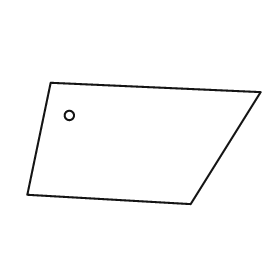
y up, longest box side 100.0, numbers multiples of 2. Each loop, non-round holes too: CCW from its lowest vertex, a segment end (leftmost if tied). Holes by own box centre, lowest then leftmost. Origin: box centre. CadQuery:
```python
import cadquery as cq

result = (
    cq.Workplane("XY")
    .moveTo(20.0, -26.0)
    .lineTo(50.0, 22.0)
    .lineTo(-40.0, 26.0)
    .lineTo(-50.0, -22.0)
    .close()
    .moveTo(-32.0, 12.0)
    .circle(2.0)
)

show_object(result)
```